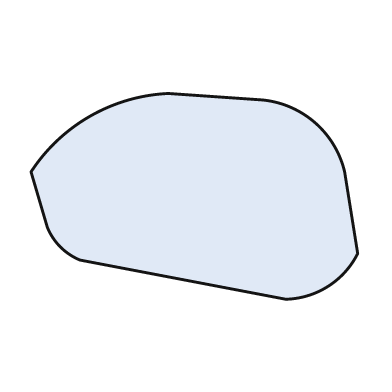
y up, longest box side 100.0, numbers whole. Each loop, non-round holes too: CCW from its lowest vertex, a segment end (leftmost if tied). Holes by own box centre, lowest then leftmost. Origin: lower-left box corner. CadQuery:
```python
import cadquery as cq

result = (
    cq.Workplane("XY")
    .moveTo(78.0, 0.0)
    .threePointArc((91.0, 4.0), (100.0, 14.0))
    .lineTo(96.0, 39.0)
    .threePointArc((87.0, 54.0), (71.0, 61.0))
    .lineTo(42.0, 63.0)
    .threePointArc((18.0, 56.0), (0.0, 39.0))
    .lineTo(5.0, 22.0)
    .threePointArc((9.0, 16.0), (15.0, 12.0))
    .close()
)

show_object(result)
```